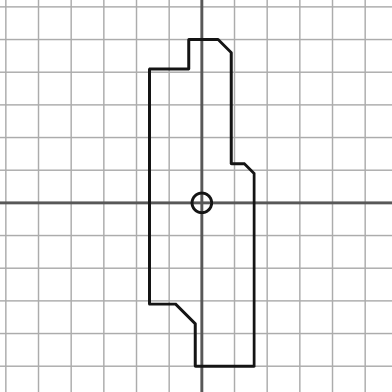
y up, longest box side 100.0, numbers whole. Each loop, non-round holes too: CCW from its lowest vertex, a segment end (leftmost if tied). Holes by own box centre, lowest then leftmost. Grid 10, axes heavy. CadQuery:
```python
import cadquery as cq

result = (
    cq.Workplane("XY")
    .moveTo(-2.0, -50.0)
    .lineTo(16.0, -50.0)
    .lineTo(16.0, 9.0)
    .lineTo(13.0, 12.0)
    .lineTo(9.0, 12.0)
    .lineTo(9.0, 46.0)
    .lineTo(5.0, 50.0)
    .lineTo(-4.0, 50.0)
    .lineTo(-4.0, 41.0)
    .lineTo(-16.0, 41.0)
    .lineTo(-16.0, -31.0)
    .lineTo(-8.0, -31.0)
    .lineTo(-2.0, -37.0)
    .close()
    .moveTo(0.0, 0.0)
    .circle(3.0)
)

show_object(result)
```